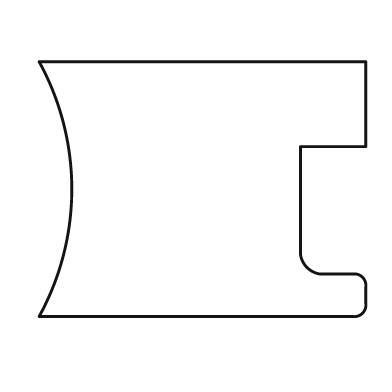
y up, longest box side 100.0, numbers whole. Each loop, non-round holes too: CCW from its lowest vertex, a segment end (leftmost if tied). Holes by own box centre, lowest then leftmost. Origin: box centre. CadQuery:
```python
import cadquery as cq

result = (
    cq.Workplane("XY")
    .moveTo(-50.0, -39.0)
    .lineTo(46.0, -39.0)
    .threePointArc((49.0, -38.0), (50.0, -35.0))
    .lineTo(50.0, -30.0)
    .threePointArc((49.0, -27.0), (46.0, -26.0))
    .lineTo(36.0, -26.0)
    .threePointArc((32.0, -24.0), (30.0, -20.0))
    .lineTo(30.0, 13.0)
    .lineTo(50.0, 13.0)
    .lineTo(50.0, 39.0)
    .lineTo(-50.0, 39.0)
    .threePointArc((-40.0, 0.0), (-50.0, -39.0))
    .close()
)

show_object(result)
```